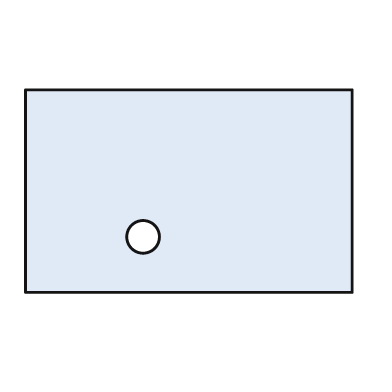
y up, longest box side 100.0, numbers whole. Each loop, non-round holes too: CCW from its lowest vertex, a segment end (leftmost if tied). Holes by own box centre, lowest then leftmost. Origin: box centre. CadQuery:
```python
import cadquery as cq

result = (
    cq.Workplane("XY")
    .moveTo(-50.0, -31.0)
    .lineTo(50.0, -31.0)
    .lineTo(50.0, 31.0)
    .lineTo(-50.0, 31.0)
    .close()
    .moveTo(-14.0, -14.0)
    .circle(5.0)
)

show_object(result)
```